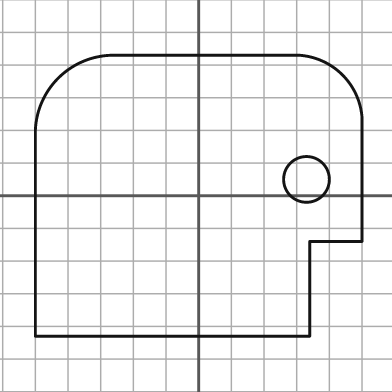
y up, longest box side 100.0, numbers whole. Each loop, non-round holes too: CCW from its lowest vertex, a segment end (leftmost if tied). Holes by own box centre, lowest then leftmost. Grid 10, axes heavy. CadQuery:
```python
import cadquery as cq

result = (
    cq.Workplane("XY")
    .moveTo(-50.0, -43.0)
    .lineTo(34.0, -43.0)
    .lineTo(34.0, -14.0)
    .lineTo(50.0, -14.0)
    .lineTo(50.0, 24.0)
    .threePointArc((44.0, 37.0), (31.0, 43.0))
    .lineTo(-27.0, 43.0)
    .threePointArc((-43.0, 36.0), (-50.0, 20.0))
    .close()
    .moveTo(33.0, 5.0)
    .circle(7.0)
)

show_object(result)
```